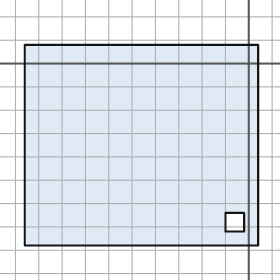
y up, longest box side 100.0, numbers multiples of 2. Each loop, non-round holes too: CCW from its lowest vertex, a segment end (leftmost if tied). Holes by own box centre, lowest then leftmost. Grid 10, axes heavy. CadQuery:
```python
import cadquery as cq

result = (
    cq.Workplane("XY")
    .moveTo(-96.0, -78.0)
    .lineTo(4.0, -78.0)
    .lineTo(4.0, 8.0)
    .lineTo(-96.0, 8.0)
    .close()
    .moveTo(-10.0, -72.0)
    .lineTo(-2.0, -72.0)
    .lineTo(-2.0, -64.0)
    .lineTo(-10.0, -64.0)
    .close()
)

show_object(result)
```